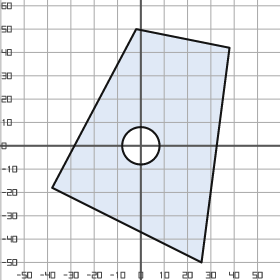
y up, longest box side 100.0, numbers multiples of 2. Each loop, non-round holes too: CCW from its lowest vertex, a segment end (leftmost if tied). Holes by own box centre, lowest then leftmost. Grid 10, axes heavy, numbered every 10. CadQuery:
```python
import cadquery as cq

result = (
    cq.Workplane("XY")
    .moveTo(26.0, -50.0)
    .lineTo(38.0, 42.0)
    .lineTo(-2.0, 50.0)
    .lineTo(-38.0, -18.0)
    .close()
    .moveTo(0.0, 0.0)
    .circle(8.0)
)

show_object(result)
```